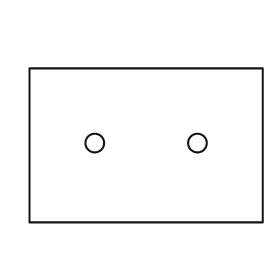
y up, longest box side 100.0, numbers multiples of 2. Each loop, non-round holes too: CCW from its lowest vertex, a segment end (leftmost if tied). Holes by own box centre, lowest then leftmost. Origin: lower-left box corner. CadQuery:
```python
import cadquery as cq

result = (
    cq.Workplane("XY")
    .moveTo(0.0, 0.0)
    .lineTo(100.0, 0.0)
    .lineTo(100.0, 66.0)
    .lineTo(0.0, 66.0)
    .close()
    .moveTo(28.0, 34.0)
    .circle(4.0)
    .moveTo(72.0, 34.0)
    .circle(4.0)
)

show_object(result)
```